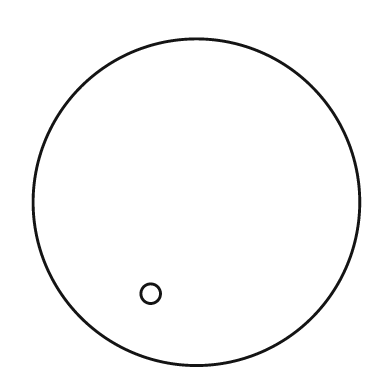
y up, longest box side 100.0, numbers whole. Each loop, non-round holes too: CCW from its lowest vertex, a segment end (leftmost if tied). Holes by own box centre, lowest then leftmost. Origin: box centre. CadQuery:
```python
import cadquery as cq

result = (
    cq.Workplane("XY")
    .moveTo(0.0, 0.0)
    .circle(50.0)
    .moveTo(-14.0, -28.0)
    .circle(3.0)
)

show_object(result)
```